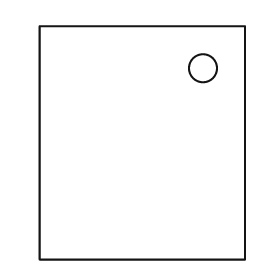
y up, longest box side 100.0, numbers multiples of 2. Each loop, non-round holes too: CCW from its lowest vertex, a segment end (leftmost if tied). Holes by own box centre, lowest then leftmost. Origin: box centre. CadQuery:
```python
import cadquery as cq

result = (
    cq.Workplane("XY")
    .moveTo(-44.0, -50.0)
    .lineTo(44.0, -50.0)
    .lineTo(44.0, 50.0)
    .lineTo(-44.0, 50.0)
    .close()
    .moveTo(26.0, 32.0)
    .circle(6.0)
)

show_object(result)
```